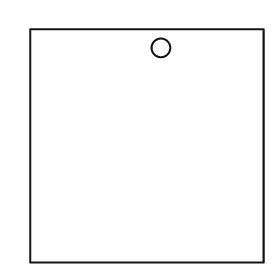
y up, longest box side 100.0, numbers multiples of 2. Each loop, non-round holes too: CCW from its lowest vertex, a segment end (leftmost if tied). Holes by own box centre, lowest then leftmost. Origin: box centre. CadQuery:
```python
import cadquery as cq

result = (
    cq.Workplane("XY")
    .moveTo(-50.0, -50.0)
    .lineTo(50.0, -50.0)
    .lineTo(50.0, 50.0)
    .lineTo(-50.0, 50.0)
    .close()
    .moveTo(6.0, 42.0)
    .circle(4.0)
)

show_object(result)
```